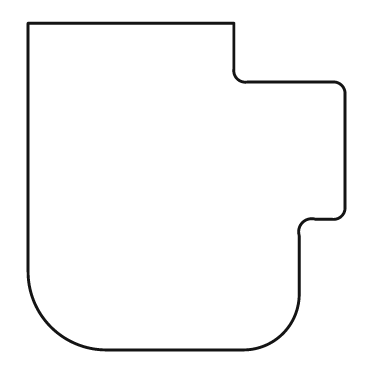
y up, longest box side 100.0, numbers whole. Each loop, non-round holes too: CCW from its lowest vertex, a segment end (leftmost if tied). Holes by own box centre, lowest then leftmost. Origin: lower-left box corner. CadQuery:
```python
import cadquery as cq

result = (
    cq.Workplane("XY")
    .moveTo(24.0, 0.0)
    .lineTo(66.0, 0.0)
    .threePointArc((78.0, 5.0), (83.0, 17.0))
    .lineTo(83.0, 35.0)
    .threePointArc((84.0, 39.0), (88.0, 40.0))
    .lineTo(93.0, 40.0)
    .threePointArc((96.0, 41.0), (97.0, 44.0))
    .lineTo(97.0, 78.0)
    .threePointArc((96.0, 81.0), (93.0, 82.0))
    .lineTo(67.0, 82.0)
    .threePointArc((64.0, 83.0), (63.0, 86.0))
    .lineTo(63.0, 100.0)
    .lineTo(0.0, 100.0)
    .lineTo(0.0, 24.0)
    .threePointArc((7.0, 7.0), (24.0, 0.0))
    .close()
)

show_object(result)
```